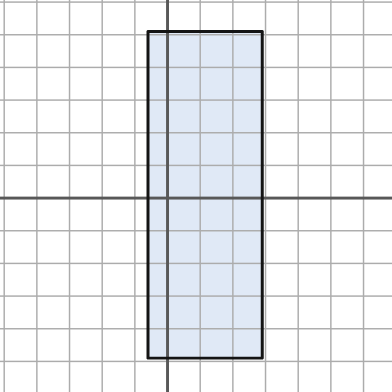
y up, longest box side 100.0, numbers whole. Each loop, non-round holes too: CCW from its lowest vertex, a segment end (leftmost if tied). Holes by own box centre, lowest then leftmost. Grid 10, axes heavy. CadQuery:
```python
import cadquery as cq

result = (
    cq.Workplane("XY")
    .moveTo(-6.0, -49.0)
    .lineTo(29.0, -49.0)
    .lineTo(29.0, 51.0)
    .lineTo(-6.0, 51.0)
    .close()
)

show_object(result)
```